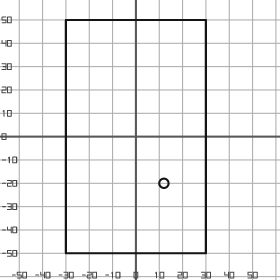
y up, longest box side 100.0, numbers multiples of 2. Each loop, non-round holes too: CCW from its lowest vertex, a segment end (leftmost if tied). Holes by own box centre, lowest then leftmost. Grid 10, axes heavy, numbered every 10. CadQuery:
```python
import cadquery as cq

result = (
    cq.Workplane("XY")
    .moveTo(-30.0, -50.0)
    .lineTo(30.0, -50.0)
    .lineTo(30.0, 50.0)
    .lineTo(-30.0, 50.0)
    .close()
    .moveTo(12.0, -20.0)
    .circle(2.0)
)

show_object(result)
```